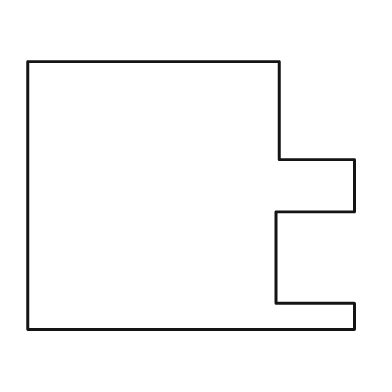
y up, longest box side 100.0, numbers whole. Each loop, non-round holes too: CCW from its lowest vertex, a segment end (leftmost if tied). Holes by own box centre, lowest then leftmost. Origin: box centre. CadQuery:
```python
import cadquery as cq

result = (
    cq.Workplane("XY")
    .moveTo(-50.0, -41.0)
    .lineTo(50.0, -41.0)
    .lineTo(50.0, -33.0)
    .lineTo(26.0, -33.0)
    .lineTo(26.0, -5.0)
    .lineTo(50.0, -5.0)
    .lineTo(50.0, 11.0)
    .lineTo(27.0, 11.0)
    .lineTo(27.0, 41.0)
    .lineTo(-50.0, 41.0)
    .close()
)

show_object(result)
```